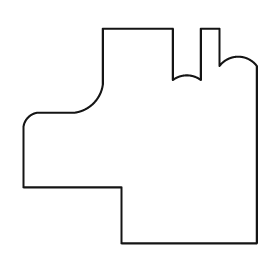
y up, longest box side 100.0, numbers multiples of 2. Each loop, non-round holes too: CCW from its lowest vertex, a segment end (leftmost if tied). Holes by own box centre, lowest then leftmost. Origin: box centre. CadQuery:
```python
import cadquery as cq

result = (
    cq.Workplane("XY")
    .moveTo(-8.0, -46.0)
    .lineTo(50.0, -46.0)
    .lineTo(50.0, 30.0)
    .threePointArc((42.0, 34.0), (34.0, 30.0))
    .lineTo(34.0, 46.0)
    .lineTo(26.0, 46.0)
    .lineTo(26.0, 24.0)
    .threePointArc((20.0, 26.0), (14.0, 24.0))
    .lineTo(14.0, 46.0)
    .lineTo(-16.0, 46.0)
    .lineTo(-16.0, 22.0)
    .threePointArc((-20.0, 14.0), (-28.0, 10.0))
    .lineTo(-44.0, 10.0)
    .threePointArc((-48.0, 8.0), (-50.0, 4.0))
    .lineTo(-50.0, -22.0)
    .lineTo(-8.0, -22.0)
    .close()
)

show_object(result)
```